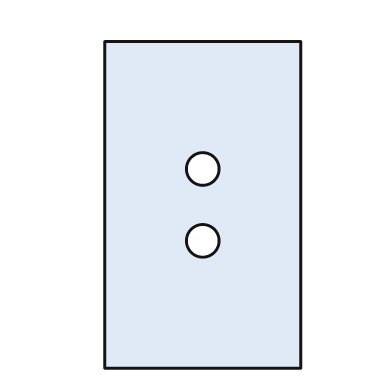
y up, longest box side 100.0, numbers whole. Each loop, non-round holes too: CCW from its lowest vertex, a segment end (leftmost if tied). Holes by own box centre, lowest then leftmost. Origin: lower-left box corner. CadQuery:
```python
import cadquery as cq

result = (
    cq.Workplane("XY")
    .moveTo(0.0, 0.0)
    .lineTo(60.0, 0.0)
    .lineTo(60.0, 100.0)
    .lineTo(0.0, 100.0)
    .close()
    .moveTo(30.0, 39.0)
    .circle(5.0)
    .moveTo(30.0, 61.0)
    .circle(5.0)
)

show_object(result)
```